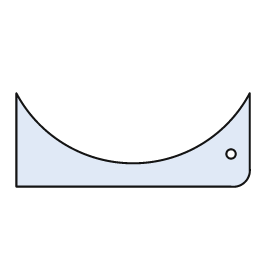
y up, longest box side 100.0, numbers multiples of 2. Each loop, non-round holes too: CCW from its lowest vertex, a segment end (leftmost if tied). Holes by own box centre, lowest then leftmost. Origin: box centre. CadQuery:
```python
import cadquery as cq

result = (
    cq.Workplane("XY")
    .moveTo(-50.0, -20.0)
    .lineTo(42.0, -20.0)
    .threePointArc((48.0, -18.0), (50.0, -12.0))
    .lineTo(50.0, 20.0)
    .threePointArc((0.0, -10.0), (-50.0, 20.0))
    .close()
    .moveTo(42.0, -6.0)
    .circle(2.0)
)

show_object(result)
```